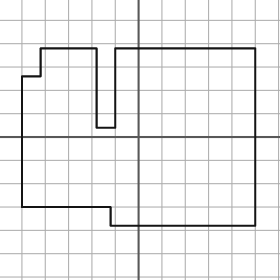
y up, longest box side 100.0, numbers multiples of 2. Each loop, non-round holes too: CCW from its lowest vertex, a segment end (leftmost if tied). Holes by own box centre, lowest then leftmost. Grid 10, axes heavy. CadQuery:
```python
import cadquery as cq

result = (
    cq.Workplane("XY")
    .moveTo(-12.0, -38.0)
    .lineTo(50.0, -38.0)
    .lineTo(50.0, 38.0)
    .lineTo(-10.0, 38.0)
    .lineTo(-10.0, 4.0)
    .lineTo(-18.0, 4.0)
    .lineTo(-18.0, 38.0)
    .lineTo(-42.0, 38.0)
    .lineTo(-42.0, 26.0)
    .lineTo(-50.0, 26.0)
    .lineTo(-50.0, -30.0)
    .lineTo(-12.0, -30.0)
    .close()
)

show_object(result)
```